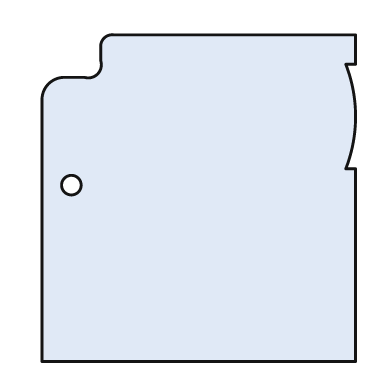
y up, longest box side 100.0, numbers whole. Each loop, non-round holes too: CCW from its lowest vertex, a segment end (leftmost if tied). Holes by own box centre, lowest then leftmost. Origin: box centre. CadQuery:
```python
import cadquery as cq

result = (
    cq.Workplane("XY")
    .moveTo(-48.0, -50.0)
    .lineTo(48.0, -50.0)
    .lineTo(48.0, 9.0)
    .lineTo(45.0, 9.0)
    .threePointArc((48.0, 25.0), (45.0, 41.0))
    .lineTo(48.0, 41.0)
    .lineTo(48.0, 50.0)
    .lineTo(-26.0, 50.0)
    .threePointArc((-29.0, 49.0), (-30.0, 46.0))
    .lineTo(-30.0, 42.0)
    .threePointArc((-31.0, 38.0), (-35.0, 37.0))
    .lineTo(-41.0, 37.0)
    .threePointArc((-46.0, 35.0), (-48.0, 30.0))
    .close()
    .moveTo(-39.0, 4.0)
    .circle(3.0)
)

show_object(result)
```